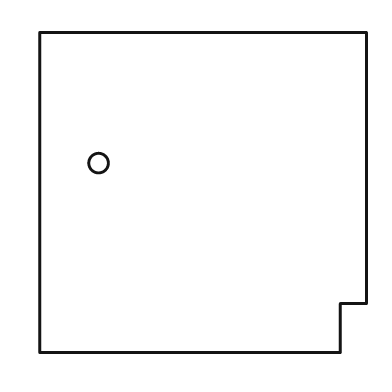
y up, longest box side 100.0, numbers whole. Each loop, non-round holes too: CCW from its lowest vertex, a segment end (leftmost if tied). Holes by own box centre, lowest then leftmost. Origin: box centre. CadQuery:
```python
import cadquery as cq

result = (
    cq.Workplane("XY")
    .moveTo(-50.0, -49.0)
    .lineTo(42.0, -49.0)
    .lineTo(42.0, -34.0)
    .lineTo(50.0, -34.0)
    .lineTo(50.0, 49.0)
    .lineTo(-50.0, 49.0)
    .close()
    .moveTo(-32.0, 9.0)
    .circle(3.0)
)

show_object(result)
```